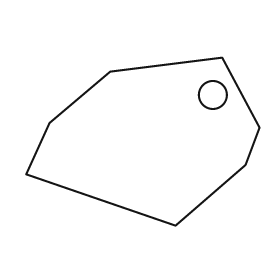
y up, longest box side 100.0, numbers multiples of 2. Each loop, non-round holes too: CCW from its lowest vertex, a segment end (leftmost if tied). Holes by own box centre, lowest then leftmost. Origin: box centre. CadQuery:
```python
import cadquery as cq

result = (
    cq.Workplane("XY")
    .moveTo(14.0, -36.0)
    .lineTo(44.0, -10.0)
    .lineTo(50.0, 6.0)
    .lineTo(34.0, 36.0)
    .lineTo(-14.0, 30.0)
    .lineTo(-40.0, 8.0)
    .lineTo(-50.0, -14.0)
    .close()
    .moveTo(30.0, 20.0)
    .circle(6.0)
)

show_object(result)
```